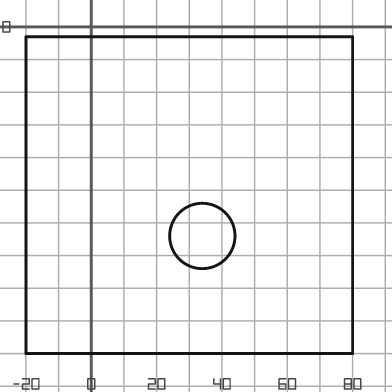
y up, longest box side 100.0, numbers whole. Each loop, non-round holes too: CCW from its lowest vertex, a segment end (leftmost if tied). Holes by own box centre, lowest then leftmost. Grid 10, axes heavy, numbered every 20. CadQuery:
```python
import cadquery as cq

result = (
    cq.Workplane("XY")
    .moveTo(-20.0, -100.0)
    .lineTo(80.0, -100.0)
    .lineTo(80.0, -3.0)
    .lineTo(-20.0, -3.0)
    .close()
    .moveTo(34.0, -64.0)
    .circle(10.0)
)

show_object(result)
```